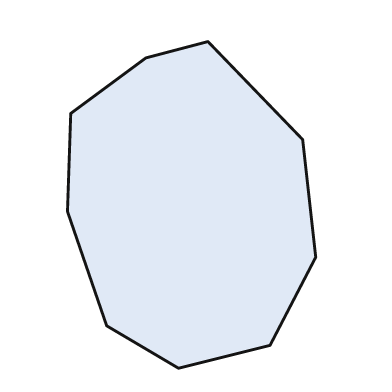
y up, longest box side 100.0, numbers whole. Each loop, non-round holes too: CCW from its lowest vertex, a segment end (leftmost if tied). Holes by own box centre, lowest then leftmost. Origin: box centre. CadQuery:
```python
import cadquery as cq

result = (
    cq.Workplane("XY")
    .moveTo(-4.0, -50.0)
    .lineTo(24.0, -43.0)
    .lineTo(38.0, -16.0)
    .lineTo(34.0, 20.0)
    .lineTo(5.0, 50.0)
    .lineTo(-14.0, 45.0)
    .lineTo(-37.0, 28.0)
    .lineTo(-38.0, -2.0)
    .lineTo(-26.0, -37.0)
    .close()
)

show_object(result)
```